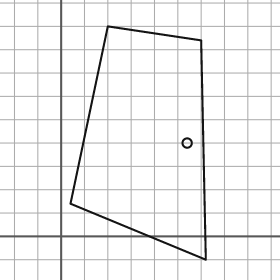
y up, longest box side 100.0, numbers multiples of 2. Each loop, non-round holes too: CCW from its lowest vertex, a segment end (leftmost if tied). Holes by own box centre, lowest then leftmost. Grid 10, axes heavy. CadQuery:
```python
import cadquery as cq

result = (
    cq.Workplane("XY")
    .moveTo(62.0, -10.0)
    .lineTo(60.0, 84.0)
    .lineTo(20.0, 90.0)
    .lineTo(4.0, 14.0)
    .close()
    .moveTo(54.0, 40.0)
    .circle(2.0)
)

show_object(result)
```